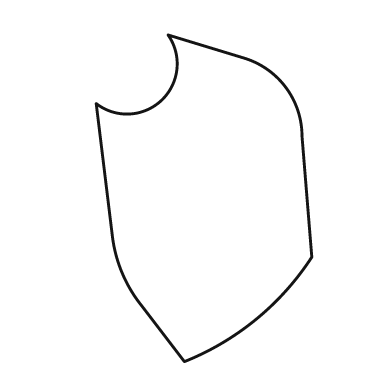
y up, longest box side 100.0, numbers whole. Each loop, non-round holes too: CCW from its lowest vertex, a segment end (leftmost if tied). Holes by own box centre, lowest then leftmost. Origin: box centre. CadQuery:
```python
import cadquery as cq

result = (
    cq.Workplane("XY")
    .moveTo(-6.0, -50.0)
    .threePointArc((16.0, -37.0), (33.0, -18.0))
    .lineTo(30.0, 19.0)
    .threePointArc((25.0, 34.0), (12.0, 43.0))
    .lineTo(-11.0, 50.0)
    .threePointArc((-13.0, 30.0), (-33.0, 29.0))
    .lineTo(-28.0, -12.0)
    .threePointArc((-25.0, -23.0), (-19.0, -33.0))
    .close()
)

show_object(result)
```